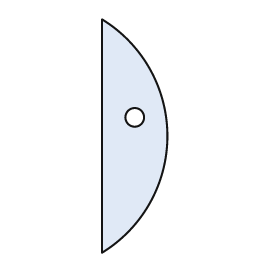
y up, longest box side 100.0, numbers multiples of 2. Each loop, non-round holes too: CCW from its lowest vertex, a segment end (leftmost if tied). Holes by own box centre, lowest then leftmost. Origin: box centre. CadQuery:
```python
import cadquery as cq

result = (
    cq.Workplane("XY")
    .moveTo(-14.0, -50.0)
    .threePointArc((14.0, 0.0), (-14.0, 50.0))
    .close()
    .moveTo(0.0, 8.0)
    .circle(4.0)
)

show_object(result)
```